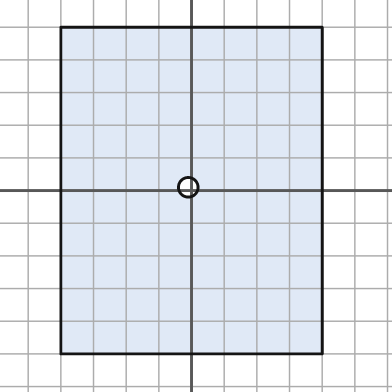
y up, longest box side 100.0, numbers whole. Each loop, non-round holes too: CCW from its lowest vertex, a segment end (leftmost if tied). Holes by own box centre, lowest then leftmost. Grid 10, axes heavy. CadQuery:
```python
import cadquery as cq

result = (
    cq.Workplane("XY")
    .moveTo(-40.0, -50.0)
    .lineTo(40.0, -50.0)
    .lineTo(40.0, 50.0)
    .lineTo(-40.0, 50.0)
    .close()
    .moveTo(-1.0, 1.0)
    .circle(3.0)
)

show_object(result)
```